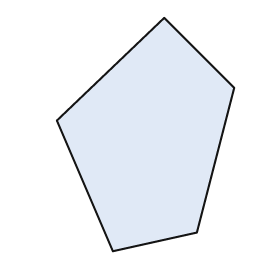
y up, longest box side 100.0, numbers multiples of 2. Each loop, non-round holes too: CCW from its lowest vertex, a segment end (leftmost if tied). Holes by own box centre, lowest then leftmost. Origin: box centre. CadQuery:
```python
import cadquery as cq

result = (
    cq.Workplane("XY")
    .moveTo(-14.0, -50.0)
    .lineTo(22.0, -42.0)
    .lineTo(38.0, 20.0)
    .lineTo(8.0, 50.0)
    .lineTo(-38.0, 6.0)
    .close()
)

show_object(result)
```